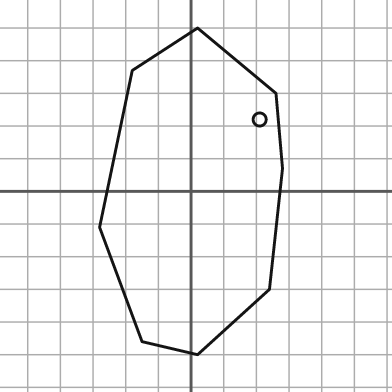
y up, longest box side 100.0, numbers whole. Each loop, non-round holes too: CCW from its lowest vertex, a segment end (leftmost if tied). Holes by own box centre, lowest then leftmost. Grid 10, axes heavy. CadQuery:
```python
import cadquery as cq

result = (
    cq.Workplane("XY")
    .moveTo(2.0, -50.0)
    .lineTo(24.0, -30.0)
    .lineTo(28.0, 7.0)
    .lineTo(26.0, 30.0)
    .lineTo(2.0, 50.0)
    .lineTo(-18.0, 37.0)
    .lineTo(-28.0, -11.0)
    .lineTo(-15.0, -46.0)
    .close()
    .moveTo(21.0, 22.0)
    .circle(2.0)
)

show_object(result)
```